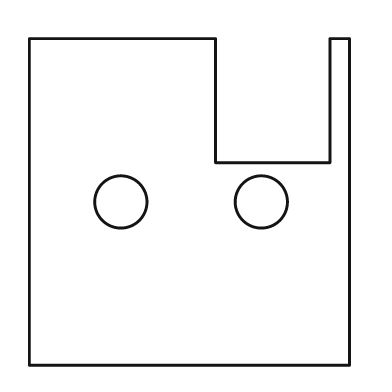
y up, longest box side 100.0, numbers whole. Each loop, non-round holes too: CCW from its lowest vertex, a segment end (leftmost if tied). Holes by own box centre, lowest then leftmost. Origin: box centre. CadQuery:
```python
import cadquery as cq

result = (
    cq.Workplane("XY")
    .moveTo(-49.0, -50.0)
    .lineTo(49.0, -50.0)
    .lineTo(49.0, 50.0)
    .lineTo(43.0, 50.0)
    .lineTo(43.0, 12.0)
    .lineTo(8.0, 12.0)
    .lineTo(8.0, 50.0)
    .lineTo(-49.0, 50.0)
    .close()
    .moveTo(-21.0, 0.0)
    .circle(8.0)
    .moveTo(22.0, 0.0)
    .circle(8.0)
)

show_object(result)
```